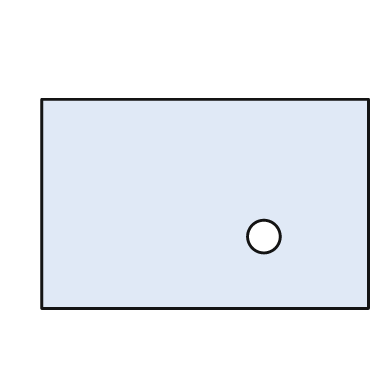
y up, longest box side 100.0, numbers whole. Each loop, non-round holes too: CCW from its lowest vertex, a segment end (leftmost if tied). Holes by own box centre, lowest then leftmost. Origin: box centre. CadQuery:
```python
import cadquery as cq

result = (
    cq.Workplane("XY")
    .moveTo(-50.0, -32.0)
    .lineTo(50.0, -32.0)
    .lineTo(50.0, 32.0)
    .lineTo(-50.0, 32.0)
    .close()
    .moveTo(18.0, -10.0)
    .circle(5.0)
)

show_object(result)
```